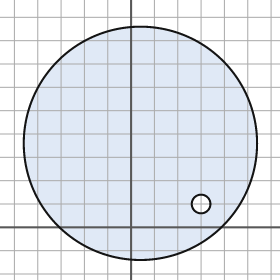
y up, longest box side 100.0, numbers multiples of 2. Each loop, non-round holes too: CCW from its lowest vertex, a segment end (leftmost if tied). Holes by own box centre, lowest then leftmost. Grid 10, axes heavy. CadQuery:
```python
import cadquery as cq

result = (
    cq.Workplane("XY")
    .moveTo(4.0, 36.0)
    .circle(50.0)
    .moveTo(30.0, 10.0)
    .circle(4.0)
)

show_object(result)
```